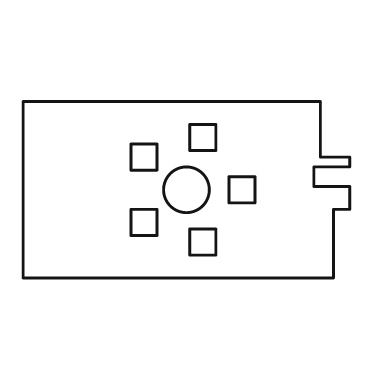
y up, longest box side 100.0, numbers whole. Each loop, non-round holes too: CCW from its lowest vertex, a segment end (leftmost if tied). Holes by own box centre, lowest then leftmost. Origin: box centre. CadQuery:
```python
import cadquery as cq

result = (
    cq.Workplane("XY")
    .moveTo(-50.0, -27.0)
    .lineTo(45.0, -27.0)
    .lineTo(45.0, -6.0)
    .lineTo(50.0, -6.0)
    .lineTo(50.0, 1.0)
    .lineTo(39.0, 1.0)
    .lineTo(39.0, 7.0)
    .lineTo(50.0, 7.0)
    .lineTo(50.0, 10.0)
    .lineTo(41.0, 10.0)
    .lineTo(41.0, 27.0)
    .lineTo(-50.0, 27.0)
    .close()
    .moveTo(1.0, -20.0)
    .lineTo(9.0, -20.0)
    .lineTo(9.0, -12.0)
    .lineTo(1.0, -12.0)
    .close()
    .moveTo(-17.0, -14.0)
    .lineTo(-9.0, -14.0)
    .lineTo(-9.0, -6.0)
    .lineTo(-17.0, -6.0)
    .close()
    .moveTo(0.0, 0.0)
    .circle(7.0)
    .moveTo(13.0, -4.0)
    .lineTo(21.0, -4.0)
    .lineTo(21.0, 4.0)
    .lineTo(13.0, 4.0)
    .close()
    .moveTo(-17.0, 6.0)
    .lineTo(-9.0, 6.0)
    .lineTo(-9.0, 14.0)
    .lineTo(-17.0, 14.0)
    .close()
    .moveTo(1.0, 12.0)
    .lineTo(9.0, 12.0)
    .lineTo(9.0, 20.0)
    .lineTo(1.0, 20.0)
    .close()
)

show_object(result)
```